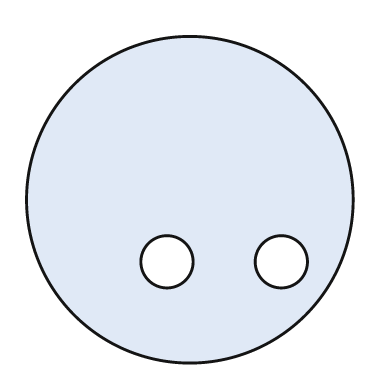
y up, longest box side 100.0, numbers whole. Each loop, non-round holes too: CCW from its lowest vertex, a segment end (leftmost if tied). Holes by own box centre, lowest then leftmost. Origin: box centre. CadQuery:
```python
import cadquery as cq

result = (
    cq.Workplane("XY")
    .moveTo(0.0, 0.0)
    .circle(50.0)
    .moveTo(-7.0, -19.0)
    .circle(8.0)
    .moveTo(28.0, -19.0)
    .circle(8.0)
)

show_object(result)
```